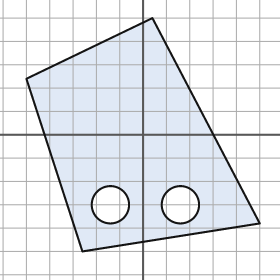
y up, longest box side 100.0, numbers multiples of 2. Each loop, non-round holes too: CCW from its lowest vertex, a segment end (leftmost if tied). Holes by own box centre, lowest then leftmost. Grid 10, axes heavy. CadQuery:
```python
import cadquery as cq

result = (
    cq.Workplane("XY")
    .moveTo(-26.0, -50.0)
    .lineTo(50.0, -38.0)
    .lineTo(4.0, 50.0)
    .lineTo(-50.0, 24.0)
    .close()
    .moveTo(-14.0, -30.0)
    .circle(8.0)
    .moveTo(16.0, -30.0)
    .circle(8.0)
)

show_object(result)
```